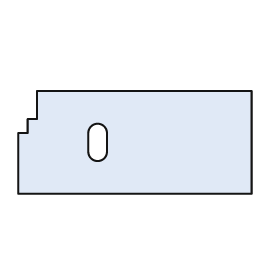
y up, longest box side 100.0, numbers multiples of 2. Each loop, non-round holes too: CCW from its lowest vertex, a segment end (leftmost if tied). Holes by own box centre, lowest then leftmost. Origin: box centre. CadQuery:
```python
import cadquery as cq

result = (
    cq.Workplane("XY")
    .moveTo(-50.0, -22.0)
    .lineTo(50.0, -22.0)
    .lineTo(50.0, 22.0)
    .lineTo(-42.0, 22.0)
    .lineTo(-42.0, 10.0)
    .lineTo(-46.0, 10.0)
    .lineTo(-46.0, 4.0)
    .lineTo(-50.0, 4.0)
    .close()
    .moveTo(-20.0, -4.0)
    .threePointArc((-16.0, -8.0), (-12.0, -4.0))
    .lineTo(-12.0, 4.0)
    .threePointArc((-16.0, 8.0), (-20.0, 4.0))
    .close()
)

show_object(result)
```